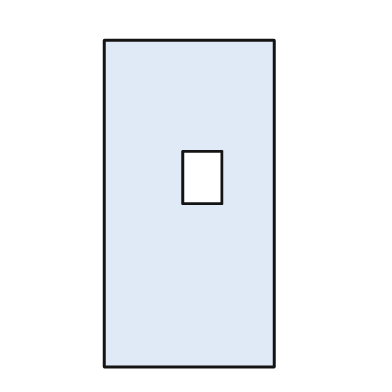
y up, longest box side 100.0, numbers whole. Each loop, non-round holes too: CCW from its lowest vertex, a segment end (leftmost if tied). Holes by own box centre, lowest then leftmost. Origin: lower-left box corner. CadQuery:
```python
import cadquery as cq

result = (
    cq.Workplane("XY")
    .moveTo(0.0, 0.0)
    .lineTo(52.0, 0.0)
    .lineTo(52.0, 100.0)
    .lineTo(0.0, 100.0)
    .close()
    .moveTo(24.0, 50.0)
    .lineTo(36.0, 50.0)
    .lineTo(36.0, 66.0)
    .lineTo(24.0, 66.0)
    .close()
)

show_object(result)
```